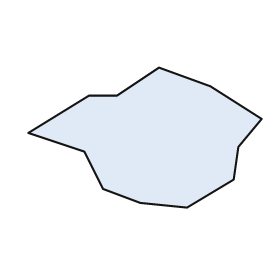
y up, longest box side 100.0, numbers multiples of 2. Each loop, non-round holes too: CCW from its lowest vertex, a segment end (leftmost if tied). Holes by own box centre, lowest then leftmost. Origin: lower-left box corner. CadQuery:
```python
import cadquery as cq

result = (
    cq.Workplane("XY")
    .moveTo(68.0, 0.0)
    .lineTo(88.0, 12.0)
    .lineTo(90.0, 26.0)
    .lineTo(100.0, 38.0)
    .lineTo(78.0, 52.0)
    .lineTo(56.0, 60.0)
    .lineTo(38.0, 48.0)
    .lineTo(26.0, 48.0)
    .lineTo(0.0, 32.0)
    .lineTo(24.0, 24.0)
    .lineTo(32.0, 8.0)
    .lineTo(48.0, 2.0)
    .close()
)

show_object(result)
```